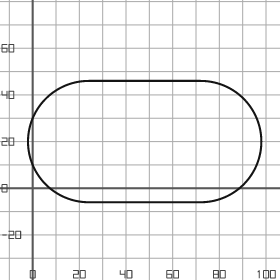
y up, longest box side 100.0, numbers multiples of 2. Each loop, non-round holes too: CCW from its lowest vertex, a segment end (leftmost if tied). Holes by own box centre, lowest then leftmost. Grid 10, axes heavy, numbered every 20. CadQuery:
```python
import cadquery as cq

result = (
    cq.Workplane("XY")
    .moveTo(24.0, -6.0)
    .lineTo(72.0, -6.0)
    .threePointArc((98.0, 20.0), (72.0, 46.0))
    .lineTo(24.0, 46.0)
    .threePointArc((-2.0, 20.0), (24.0, -6.0))
    .close()
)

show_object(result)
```